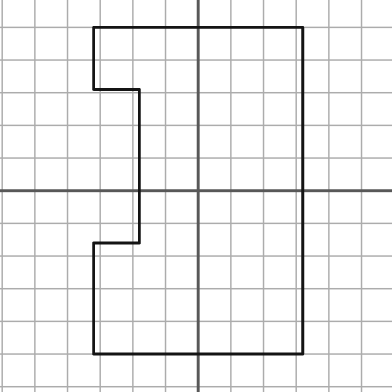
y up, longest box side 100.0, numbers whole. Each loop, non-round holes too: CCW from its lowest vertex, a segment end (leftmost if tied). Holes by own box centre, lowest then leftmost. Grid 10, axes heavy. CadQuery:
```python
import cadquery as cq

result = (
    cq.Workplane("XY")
    .moveTo(-32.0, -50.0)
    .lineTo(32.0, -50.0)
    .lineTo(32.0, 50.0)
    .lineTo(-32.0, 50.0)
    .lineTo(-32.0, 31.0)
    .lineTo(-18.0, 31.0)
    .lineTo(-18.0, -16.0)
    .lineTo(-32.0, -16.0)
    .close()
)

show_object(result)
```